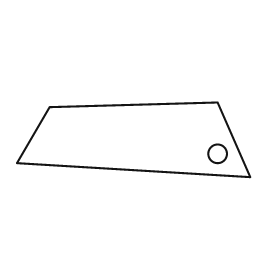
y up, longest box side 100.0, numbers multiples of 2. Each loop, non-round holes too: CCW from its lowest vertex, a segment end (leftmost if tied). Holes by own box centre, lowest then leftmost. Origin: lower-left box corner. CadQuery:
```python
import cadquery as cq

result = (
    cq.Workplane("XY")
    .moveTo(100.0, 0.0)
    .lineTo(86.0, 32.0)
    .lineTo(14.0, 30.0)
    .lineTo(0.0, 6.0)
    .close()
    .moveTo(86.0, 10.0)
    .circle(4.0)
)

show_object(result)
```